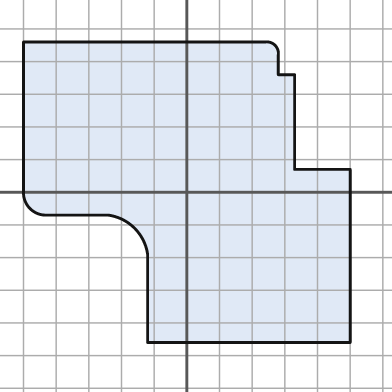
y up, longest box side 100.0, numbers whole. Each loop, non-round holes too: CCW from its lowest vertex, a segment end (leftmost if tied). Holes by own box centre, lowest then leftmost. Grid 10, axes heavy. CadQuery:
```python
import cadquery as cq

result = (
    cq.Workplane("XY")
    .moveTo(-12.0, -46.0)
    .lineTo(50.0, -46.0)
    .lineTo(50.0, 7.0)
    .lineTo(33.0, 7.0)
    .lineTo(33.0, 36.0)
    .lineTo(28.0, 36.0)
    .lineTo(28.0, 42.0)
    .threePointArc((27.0, 45.0), (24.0, 46.0))
    .lineTo(-50.0, 46.0)
    .lineTo(-50.0, 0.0)
    .threePointArc((-48.0, -5.0), (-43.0, -7.0))
    .lineTo(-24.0, -7.0)
    .threePointArc((-16.0, -11.0), (-12.0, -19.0))
    .close()
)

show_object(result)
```